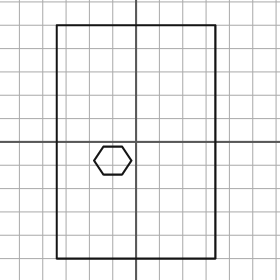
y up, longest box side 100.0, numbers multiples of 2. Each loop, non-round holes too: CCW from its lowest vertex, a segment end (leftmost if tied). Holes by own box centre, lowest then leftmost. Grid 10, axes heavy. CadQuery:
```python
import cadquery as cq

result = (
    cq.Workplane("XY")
    .moveTo(-34.0, -50.0)
    .lineTo(34.0, -50.0)
    .lineTo(34.0, 50.0)
    .lineTo(-34.0, 50.0)
    .close()
    .moveTo(-14.0, -14.0)
    .lineTo(-6.0, -14.0)
    .lineTo(-2.0, -8.0)
    .lineTo(-6.0, -2.0)
    .lineTo(-14.0, -2.0)
    .lineTo(-18.0, -8.0)
    .close()
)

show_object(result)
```